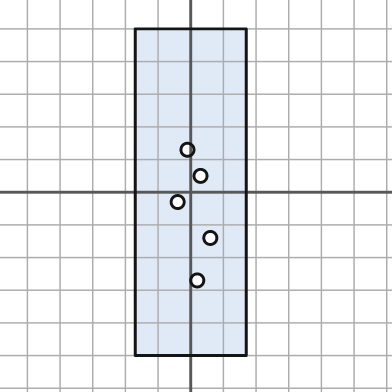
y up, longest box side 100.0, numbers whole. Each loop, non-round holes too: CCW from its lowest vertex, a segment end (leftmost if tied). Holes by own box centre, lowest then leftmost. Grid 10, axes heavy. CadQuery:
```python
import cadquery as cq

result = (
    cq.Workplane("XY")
    .moveTo(-17.0, -50.0)
    .lineTo(17.0, -50.0)
    .lineTo(17.0, 50.0)
    .lineTo(-17.0, 50.0)
    .close()
    .moveTo(2.0, -27.0)
    .circle(2.0)
    .moveTo(6.0, -14.0)
    .circle(2.0)
    .moveTo(-4.0, -3.0)
    .circle(2.0)
    .moveTo(3.0, 5.0)
    .circle(2.0)
    .moveTo(-1.0, 13.0)
    .circle(2.0)
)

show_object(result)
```